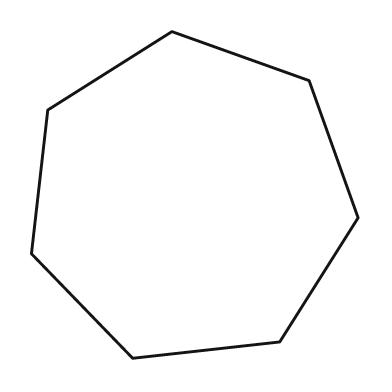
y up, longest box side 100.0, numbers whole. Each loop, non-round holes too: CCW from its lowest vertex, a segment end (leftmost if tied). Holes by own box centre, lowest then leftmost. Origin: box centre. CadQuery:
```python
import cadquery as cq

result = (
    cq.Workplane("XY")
    .moveTo(-19.0, -50.0)
    .lineTo(26.0, -45.0)
    .lineTo(50.0, -7.0)
    .lineTo(35.0, 35.0)
    .lineTo(-7.0, 50.0)
    .lineTo(-45.0, 26.0)
    .lineTo(-50.0, -18.0)
    .close()
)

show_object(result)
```